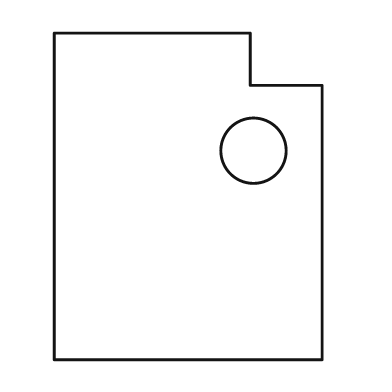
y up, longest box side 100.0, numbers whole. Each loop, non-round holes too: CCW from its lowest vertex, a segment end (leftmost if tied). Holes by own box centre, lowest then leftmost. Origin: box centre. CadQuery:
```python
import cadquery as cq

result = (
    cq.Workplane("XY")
    .moveTo(-41.0, -50.0)
    .lineTo(41.0, -50.0)
    .lineTo(41.0, 34.0)
    .lineTo(19.0, 34.0)
    .lineTo(19.0, 50.0)
    .lineTo(-41.0, 50.0)
    .close()
    .moveTo(20.0, 14.0)
    .circle(10.0)
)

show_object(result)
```